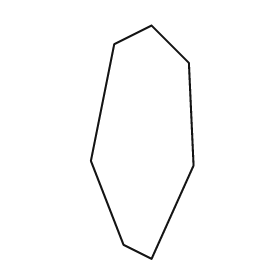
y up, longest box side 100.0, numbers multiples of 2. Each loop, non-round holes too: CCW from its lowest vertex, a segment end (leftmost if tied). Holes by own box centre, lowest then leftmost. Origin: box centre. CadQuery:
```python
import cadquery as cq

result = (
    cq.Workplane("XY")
    .moveTo(4.0, -50.0)
    .lineTo(22.0, -10.0)
    .lineTo(20.0, 34.0)
    .lineTo(4.0, 50.0)
    .lineTo(-12.0, 42.0)
    .lineTo(-22.0, -8.0)
    .lineTo(-8.0, -44.0)
    .close()
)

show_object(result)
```